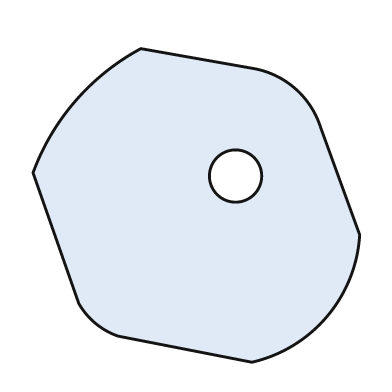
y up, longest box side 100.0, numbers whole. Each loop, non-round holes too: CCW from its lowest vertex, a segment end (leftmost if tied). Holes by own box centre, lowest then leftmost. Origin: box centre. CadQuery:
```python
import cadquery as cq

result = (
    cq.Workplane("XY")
    .moveTo(17.0, -48.0)
    .threePointArc((40.0, -34.0), (50.0, -9.0))
    .lineTo(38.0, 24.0)
    .threePointArc((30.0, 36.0), (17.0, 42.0))
    .lineTo(-17.0, 48.0)
    .threePointArc((-37.0, 32.0), (-50.0, 10.0))
    .lineTo(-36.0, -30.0)
    .threePointArc((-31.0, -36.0), (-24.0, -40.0))
    .close()
    .moveTo(12.0, 9.0)
    .circle(8.0)
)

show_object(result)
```